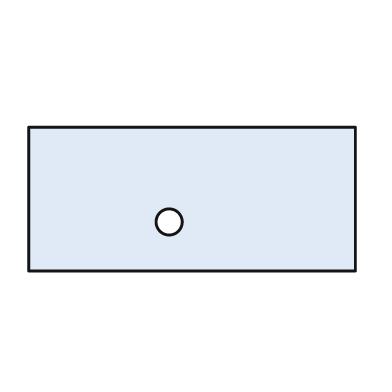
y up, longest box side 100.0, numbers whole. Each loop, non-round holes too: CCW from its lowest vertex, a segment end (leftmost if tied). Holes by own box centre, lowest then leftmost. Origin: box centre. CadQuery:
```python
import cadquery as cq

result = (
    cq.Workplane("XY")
    .moveTo(-50.0, -22.0)
    .lineTo(50.0, -22.0)
    .lineTo(50.0, 22.0)
    .lineTo(-50.0, 22.0)
    .close()
    .moveTo(-7.0, -7.0)
    .circle(4.0)
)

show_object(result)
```